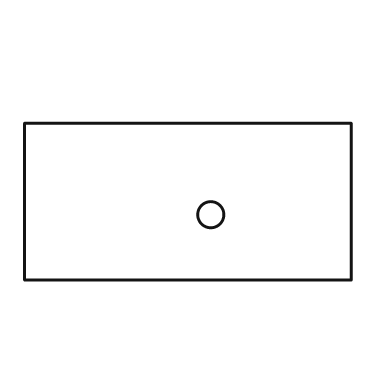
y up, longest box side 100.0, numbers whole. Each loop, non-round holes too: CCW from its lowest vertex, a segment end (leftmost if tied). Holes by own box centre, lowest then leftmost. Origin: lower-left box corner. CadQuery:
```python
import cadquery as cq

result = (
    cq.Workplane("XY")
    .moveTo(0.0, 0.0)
    .lineTo(100.0, 0.0)
    .lineTo(100.0, 48.0)
    .lineTo(0.0, 48.0)
    .close()
    .moveTo(57.0, 20.0)
    .circle(4.0)
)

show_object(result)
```